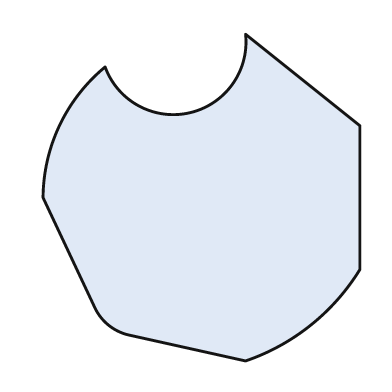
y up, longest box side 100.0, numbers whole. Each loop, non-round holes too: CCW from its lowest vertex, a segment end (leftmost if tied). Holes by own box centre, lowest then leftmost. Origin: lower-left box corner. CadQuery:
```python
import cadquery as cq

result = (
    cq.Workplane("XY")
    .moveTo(62.0, 0.0)
    .threePointArc((82.0, 11.0), (97.0, 28.0))
    .lineTo(97.0, 72.0)
    .lineTo(62.0, 100.0)
    .threePointArc((45.0, 76.0), (19.0, 90.0))
    .threePointArc((5.0, 72.0), (0.0, 50.0))
    .lineTo(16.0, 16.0)
    .threePointArc((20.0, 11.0), (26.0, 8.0))
    .close()
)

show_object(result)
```